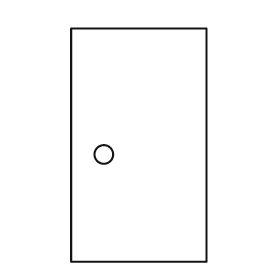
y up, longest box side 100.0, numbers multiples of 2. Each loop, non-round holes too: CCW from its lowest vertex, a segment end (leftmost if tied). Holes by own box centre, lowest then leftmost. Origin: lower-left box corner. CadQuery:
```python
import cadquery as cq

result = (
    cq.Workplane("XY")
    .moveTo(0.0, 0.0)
    .lineTo(58.0, 0.0)
    .lineTo(58.0, 100.0)
    .lineTo(0.0, 100.0)
    .close()
    .moveTo(14.0, 46.0)
    .circle(4.0)
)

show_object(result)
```